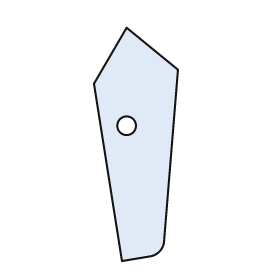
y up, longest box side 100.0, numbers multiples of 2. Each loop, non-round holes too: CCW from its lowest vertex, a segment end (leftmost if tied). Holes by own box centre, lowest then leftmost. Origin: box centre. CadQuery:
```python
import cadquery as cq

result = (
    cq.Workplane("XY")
    .moveTo(-6.0, -50.0)
    .lineTo(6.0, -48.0)
    .threePointArc((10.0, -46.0), (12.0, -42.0))
    .lineTo(18.0, 32.0)
    .lineTo(-4.0, 50.0)
    .lineTo(-18.0, 26.0)
    .close()
    .moveTo(-4.0, 8.0)
    .circle(4.0)
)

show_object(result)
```